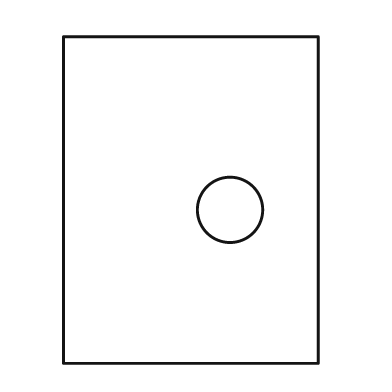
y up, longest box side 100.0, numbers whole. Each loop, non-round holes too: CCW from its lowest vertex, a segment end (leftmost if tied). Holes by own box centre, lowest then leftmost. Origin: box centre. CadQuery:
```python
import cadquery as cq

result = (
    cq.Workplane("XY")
    .moveTo(-39.0, -50.0)
    .lineTo(39.0, -50.0)
    .lineTo(39.0, 50.0)
    .lineTo(-39.0, 50.0)
    .close()
    .moveTo(12.0, -3.0)
    .circle(10.0)
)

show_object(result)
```